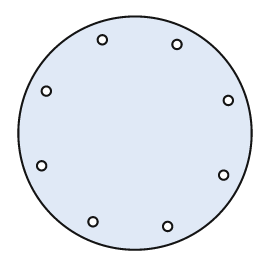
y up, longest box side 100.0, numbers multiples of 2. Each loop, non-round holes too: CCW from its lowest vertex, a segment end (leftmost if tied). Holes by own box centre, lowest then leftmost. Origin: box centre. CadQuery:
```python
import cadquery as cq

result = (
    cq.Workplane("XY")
    .moveTo(0.0, 0.0)
    .circle(50.0)
    .moveTo(14.0, -40.0)
    .circle(2.0)
    .moveTo(-18.0, -38.0)
    .circle(2.0)
    .moveTo(38.0, -18.0)
    .circle(2.0)
    .moveTo(-40.0, -14.0)
    .circle(2.0)
    .moveTo(40.0, 14.0)
    .circle(2.0)
    .moveTo(-38.0, 18.0)
    .circle(2.0)
    .moveTo(18.0, 38.0)
    .circle(2.0)
    .moveTo(-14.0, 40.0)
    .circle(2.0)
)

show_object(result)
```